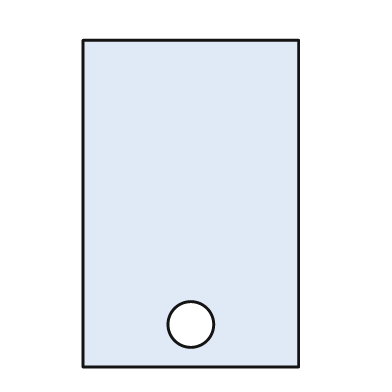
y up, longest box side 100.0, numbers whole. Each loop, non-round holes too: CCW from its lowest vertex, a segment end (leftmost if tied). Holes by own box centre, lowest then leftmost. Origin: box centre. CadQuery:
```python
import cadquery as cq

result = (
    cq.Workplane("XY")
    .moveTo(-33.0, -50.0)
    .lineTo(33.0, -50.0)
    .lineTo(33.0, 50.0)
    .lineTo(-33.0, 50.0)
    .close()
    .moveTo(0.0, -37.0)
    .circle(7.0)
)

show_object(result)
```